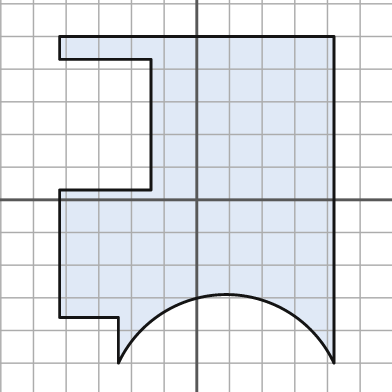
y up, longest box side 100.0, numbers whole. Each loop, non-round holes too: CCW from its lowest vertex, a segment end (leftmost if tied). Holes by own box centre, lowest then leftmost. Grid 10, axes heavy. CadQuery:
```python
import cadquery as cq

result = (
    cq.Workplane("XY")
    .moveTo(-24.0, -50.0)
    .threePointArc((9.0, -29.0), (42.0, -50.0))
    .lineTo(42.0, 50.0)
    .lineTo(-42.0, 50.0)
    .lineTo(-42.0, 43.0)
    .lineTo(-14.0, 43.0)
    .lineTo(-14.0, 3.0)
    .lineTo(-42.0, 3.0)
    .lineTo(-42.0, -36.0)
    .lineTo(-24.0, -36.0)
    .close()
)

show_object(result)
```